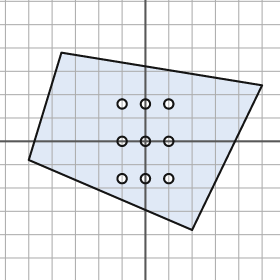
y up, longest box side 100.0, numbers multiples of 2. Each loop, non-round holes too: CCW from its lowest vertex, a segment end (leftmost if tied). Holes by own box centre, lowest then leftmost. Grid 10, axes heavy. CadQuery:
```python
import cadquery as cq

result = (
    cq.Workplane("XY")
    .moveTo(20.0, -38.0)
    .lineTo(50.0, 24.0)
    .lineTo(-36.0, 38.0)
    .lineTo(-50.0, -8.0)
    .close()
    .moveTo(-10.0, -16.0)
    .circle(2.0)
    .moveTo(0.0, -16.0)
    .circle(2.0)
    .moveTo(10.0, -16.0)
    .circle(2.0)
    .moveTo(-10.0, 0.0)
    .circle(2.0)
    .moveTo(0.0, 0.0)
    .circle(2.0)
    .moveTo(10.0, 0.0)
    .circle(2.0)
    .moveTo(-10.0, 16.0)
    .circle(2.0)
    .moveTo(0.0, 16.0)
    .circle(2.0)
    .moveTo(10.0, 16.0)
    .circle(2.0)
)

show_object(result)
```